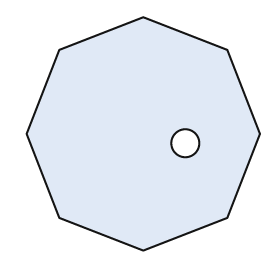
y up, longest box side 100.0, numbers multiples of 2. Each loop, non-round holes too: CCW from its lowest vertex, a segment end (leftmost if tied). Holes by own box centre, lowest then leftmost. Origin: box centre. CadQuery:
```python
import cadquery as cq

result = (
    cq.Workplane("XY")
    .moveTo(0.0, -50.0)
    .lineTo(36.0, -36.0)
    .lineTo(50.0, 0.0)
    .lineTo(36.0, 36.0)
    .lineTo(0.0, 50.0)
    .lineTo(-36.0, 36.0)
    .lineTo(-50.0, 0.0)
    .lineTo(-36.0, -36.0)
    .close()
    .moveTo(18.0, -4.0)
    .circle(6.0)
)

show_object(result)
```